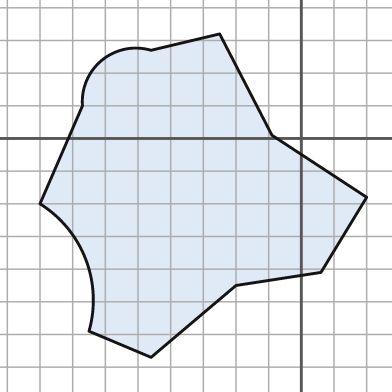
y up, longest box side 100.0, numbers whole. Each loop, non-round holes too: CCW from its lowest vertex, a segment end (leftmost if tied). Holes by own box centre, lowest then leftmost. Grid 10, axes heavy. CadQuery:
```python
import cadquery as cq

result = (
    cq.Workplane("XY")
    .moveTo(-46.0, -67.0)
    .lineTo(-20.0, -45.0)
    .lineTo(6.0, -41.0)
    .lineTo(20.0, -18.0)
    .lineTo(-9.0, 1.0)
    .lineTo(-25.0, 32.0)
    .lineTo(-46.0, 27.0)
    .threePointArc((-61.0, 24.0), (-67.0, 10.0))
    .lineTo(-80.0, -20.0)
    .threePointArc((-66.0, -37.0), (-65.0, -59.0))
    .close()
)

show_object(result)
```